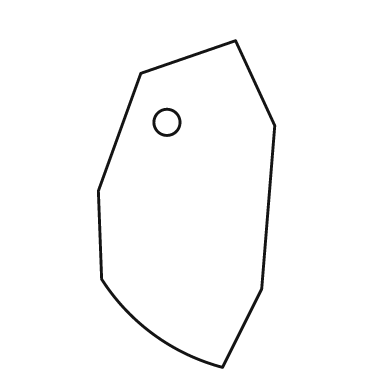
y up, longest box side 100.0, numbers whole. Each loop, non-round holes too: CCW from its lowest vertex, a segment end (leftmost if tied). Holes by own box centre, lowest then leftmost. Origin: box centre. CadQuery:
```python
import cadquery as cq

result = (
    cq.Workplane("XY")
    .moveTo(11.0, -50.0)
    .lineTo(23.0, -26.0)
    .lineTo(27.0, 24.0)
    .lineTo(15.0, 50.0)
    .lineTo(-14.0, 40.0)
    .lineTo(-27.0, 4.0)
    .lineTo(-26.0, -23.0)
    .threePointArc((-10.0, -40.0), (11.0, -50.0))
    .close()
    .moveTo(-6.0, 25.0)
    .circle(4.0)
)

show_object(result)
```